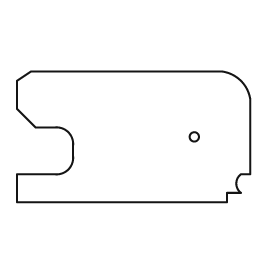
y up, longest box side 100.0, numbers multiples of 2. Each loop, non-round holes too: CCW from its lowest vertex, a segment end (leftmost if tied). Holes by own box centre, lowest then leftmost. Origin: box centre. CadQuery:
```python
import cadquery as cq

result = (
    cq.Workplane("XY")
    .moveTo(-50.0, -28.0)
    .lineTo(40.0, -28.0)
    .lineTo(40.0, -24.0)
    .lineTo(46.0, -24.0)
    .threePointArc((44.0, -20.0), (46.0, -16.0))
    .lineTo(50.0, -16.0)
    .lineTo(50.0, 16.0)
    .threePointArc((46.0, 24.0), (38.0, 28.0))
    .lineTo(-44.0, 28.0)
    .lineTo(-50.0, 24.0)
    .lineTo(-50.0, 12.0)
    .lineTo(-42.0, 4.0)
    .lineTo(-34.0, 4.0)
    .threePointArc((-28.0, 2.0), (-26.0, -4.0))
    .lineTo(-26.0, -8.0)
    .threePointArc((-28.0, -14.0), (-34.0, -16.0))
    .lineTo(-50.0, -16.0)
    .close()
    .moveTo(26.0, 0.0)
    .circle(2.0)
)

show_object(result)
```